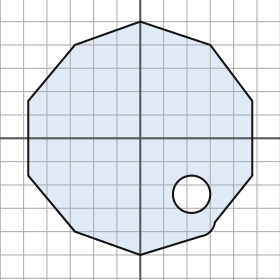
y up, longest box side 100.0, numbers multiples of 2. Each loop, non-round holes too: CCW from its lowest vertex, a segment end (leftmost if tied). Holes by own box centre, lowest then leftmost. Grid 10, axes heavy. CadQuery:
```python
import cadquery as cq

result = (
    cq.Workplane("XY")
    .moveTo(0.0, -50.0)
    .lineTo(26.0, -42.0)
    .threePointArc((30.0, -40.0), (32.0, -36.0))
    .lineTo(48.0, -16.0)
    .lineTo(48.0, 16.0)
    .lineTo(30.0, 40.0)
    .lineTo(0.0, 50.0)
    .lineTo(-28.0, 40.0)
    .lineTo(-48.0, 16.0)
    .lineTo(-48.0, -16.0)
    .lineTo(-28.0, -40.0)
    .close()
    .moveTo(22.0, -24.0)
    .circle(8.0)
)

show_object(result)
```